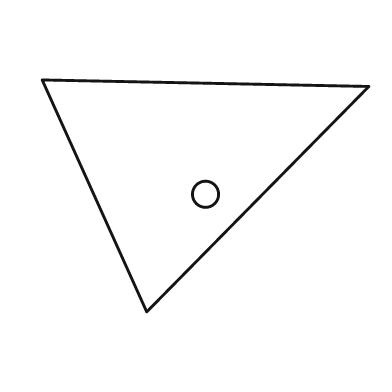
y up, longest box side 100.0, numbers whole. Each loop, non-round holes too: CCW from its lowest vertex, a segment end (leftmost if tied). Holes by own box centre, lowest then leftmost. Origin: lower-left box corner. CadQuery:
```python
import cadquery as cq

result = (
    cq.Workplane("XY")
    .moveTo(32.0, 0.0)
    .lineTo(100.0, 69.0)
    .lineTo(0.0, 71.0)
    .close()
    .moveTo(50.0, 36.0)
    .circle(4.0)
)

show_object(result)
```